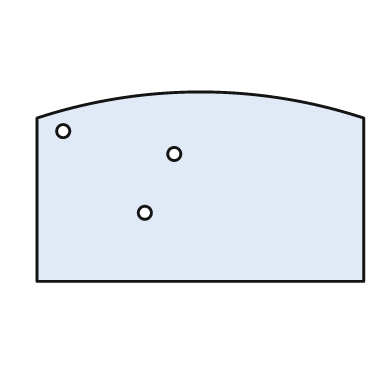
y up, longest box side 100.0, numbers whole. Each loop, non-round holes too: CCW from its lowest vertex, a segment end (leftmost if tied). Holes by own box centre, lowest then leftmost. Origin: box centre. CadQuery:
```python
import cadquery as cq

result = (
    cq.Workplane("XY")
    .moveTo(-50.0, -29.0)
    .lineTo(50.0, -29.0)
    .lineTo(50.0, 21.0)
    .threePointArc((0.0, 29.0), (-50.0, 21.0))
    .close()
    .moveTo(-17.0, -8.0)
    .circle(2.0)
    .moveTo(-8.0, 10.0)
    .circle(2.0)
    .moveTo(-42.0, 17.0)
    .circle(2.0)
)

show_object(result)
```